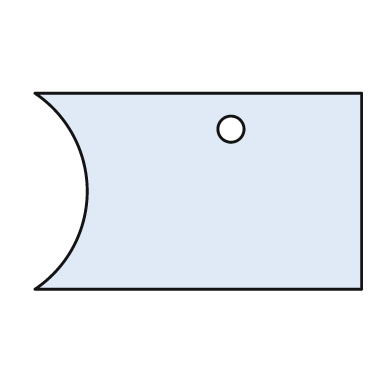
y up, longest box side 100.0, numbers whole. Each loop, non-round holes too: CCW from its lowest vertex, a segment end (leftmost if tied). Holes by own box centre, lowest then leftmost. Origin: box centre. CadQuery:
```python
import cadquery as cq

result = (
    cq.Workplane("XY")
    .moveTo(-50.0, -30.0)
    .lineTo(50.0, -30.0)
    .lineTo(50.0, 30.0)
    .lineTo(-50.0, 30.0)
    .threePointArc((-34.0, 0.0), (-50.0, -30.0))
    .close()
    .moveTo(10.0, 19.0)
    .circle(4.0)
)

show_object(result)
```